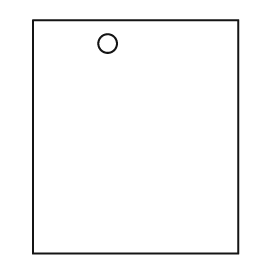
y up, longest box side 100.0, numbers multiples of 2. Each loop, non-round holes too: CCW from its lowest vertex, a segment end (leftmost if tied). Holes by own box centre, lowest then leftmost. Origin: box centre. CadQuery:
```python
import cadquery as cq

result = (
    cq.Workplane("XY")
    .moveTo(-44.0, -50.0)
    .lineTo(44.0, -50.0)
    .lineTo(44.0, 50.0)
    .lineTo(-44.0, 50.0)
    .close()
    .moveTo(-12.0, 40.0)
    .circle(4.0)
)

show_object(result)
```